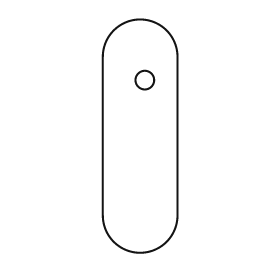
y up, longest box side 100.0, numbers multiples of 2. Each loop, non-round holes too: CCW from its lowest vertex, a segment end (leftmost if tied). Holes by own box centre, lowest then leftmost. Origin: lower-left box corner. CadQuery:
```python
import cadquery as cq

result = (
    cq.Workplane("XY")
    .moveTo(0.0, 16.0)
    .threePointArc((16.0, 0.0), (32.0, 16.0))
    .lineTo(32.0, 84.0)
    .threePointArc((16.0, 100.0), (0.0, 84.0))
    .close()
    .moveTo(18.0, 74.0)
    .circle(4.0)
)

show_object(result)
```